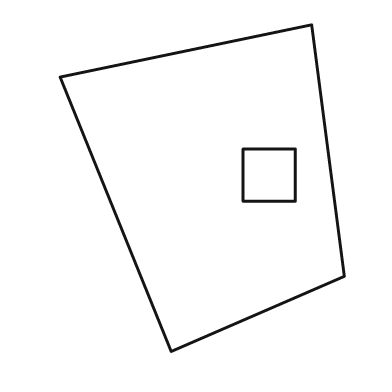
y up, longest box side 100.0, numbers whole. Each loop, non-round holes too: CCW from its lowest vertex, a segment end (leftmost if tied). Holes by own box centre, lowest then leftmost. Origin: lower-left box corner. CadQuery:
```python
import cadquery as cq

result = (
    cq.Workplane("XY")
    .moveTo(34.0, 0.0)
    .lineTo(87.0, 23.0)
    .lineTo(77.0, 100.0)
    .lineTo(0.0, 84.0)
    .close()
    .moveTo(56.0, 46.0)
    .lineTo(72.0, 46.0)
    .lineTo(72.0, 62.0)
    .lineTo(56.0, 62.0)
    .close()
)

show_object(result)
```